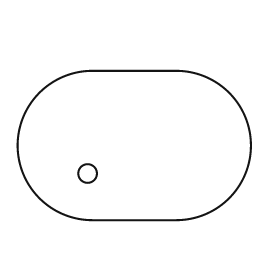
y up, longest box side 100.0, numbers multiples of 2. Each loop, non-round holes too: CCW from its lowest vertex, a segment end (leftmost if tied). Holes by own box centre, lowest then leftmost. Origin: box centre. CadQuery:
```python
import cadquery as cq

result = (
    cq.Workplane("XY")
    .moveTo(-18.0, -32.0)
    .lineTo(18.0, -32.0)
    .threePointArc((50.0, 0.0), (18.0, 32.0))
    .lineTo(-18.0, 32.0)
    .threePointArc((-50.0, 0.0), (-18.0, -32.0))
    .close()
    .moveTo(-20.0, -12.0)
    .circle(4.0)
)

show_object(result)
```